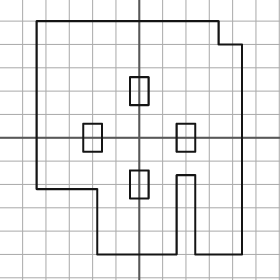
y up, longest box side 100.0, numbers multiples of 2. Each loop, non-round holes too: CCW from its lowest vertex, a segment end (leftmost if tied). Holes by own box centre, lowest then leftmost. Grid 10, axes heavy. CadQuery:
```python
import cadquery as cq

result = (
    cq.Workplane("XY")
    .moveTo(-18.0, -50.0)
    .lineTo(16.0, -50.0)
    .lineTo(16.0, -16.0)
    .lineTo(24.0, -16.0)
    .lineTo(24.0, -50.0)
    .lineTo(44.0, -50.0)
    .lineTo(44.0, 40.0)
    .lineTo(34.0, 40.0)
    .lineTo(34.0, 50.0)
    .lineTo(-44.0, 50.0)
    .lineTo(-44.0, -22.0)
    .lineTo(-18.0, -22.0)
    .close()
    .moveTo(-4.0, -26.0)
    .lineTo(4.0, -26.0)
    .lineTo(4.0, -14.0)
    .lineTo(-4.0, -14.0)
    .close()
    .moveTo(-24.0, -6.0)
    .lineTo(-16.0, -6.0)
    .lineTo(-16.0, 6.0)
    .lineTo(-24.0, 6.0)
    .close()
    .moveTo(16.0, -6.0)
    .lineTo(24.0, -6.0)
    .lineTo(24.0, 6.0)
    .lineTo(16.0, 6.0)
    .close()
    .moveTo(-4.0, 14.0)
    .lineTo(4.0, 14.0)
    .lineTo(4.0, 26.0)
    .lineTo(-4.0, 26.0)
    .close()
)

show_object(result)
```